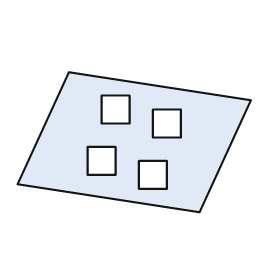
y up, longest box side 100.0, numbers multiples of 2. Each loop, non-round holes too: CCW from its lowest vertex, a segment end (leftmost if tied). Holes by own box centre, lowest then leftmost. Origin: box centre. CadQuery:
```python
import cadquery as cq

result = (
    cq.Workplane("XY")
    .moveTo(28.0, -30.0)
    .lineTo(50.0, 18.0)
    .lineTo(-28.0, 30.0)
    .lineTo(-50.0, -18.0)
    .close()
    .moveTo(2.0, -20.0)
    .lineTo(14.0, -20.0)
    .lineTo(14.0, -8.0)
    .lineTo(2.0, -8.0)
    .close()
    .moveTo(-20.0, -14.0)
    .lineTo(-8.0, -14.0)
    .lineTo(-8.0, -2.0)
    .lineTo(-20.0, -2.0)
    .close()
    .moveTo(8.0, 2.0)
    .lineTo(20.0, 2.0)
    .lineTo(20.0, 14.0)
    .lineTo(8.0, 14.0)
    .close()
    .moveTo(-14.0, 8.0)
    .lineTo(-2.0, 8.0)
    .lineTo(-2.0, 20.0)
    .lineTo(-14.0, 20.0)
    .close()
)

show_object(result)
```